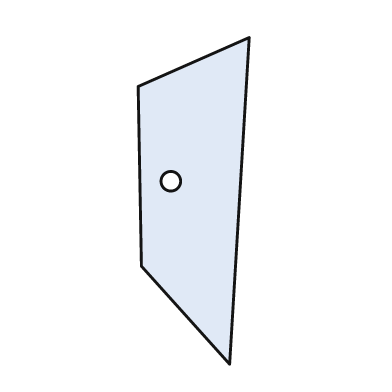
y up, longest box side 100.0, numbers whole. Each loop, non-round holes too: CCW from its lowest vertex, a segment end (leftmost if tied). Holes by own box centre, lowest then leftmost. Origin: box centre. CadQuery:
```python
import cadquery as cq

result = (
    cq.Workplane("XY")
    .moveTo(11.0, -50.0)
    .lineTo(17.0, 50.0)
    .lineTo(-17.0, 35.0)
    .lineTo(-16.0, -20.0)
    .close()
    .moveTo(-7.0, 6.0)
    .circle(3.0)
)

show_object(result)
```